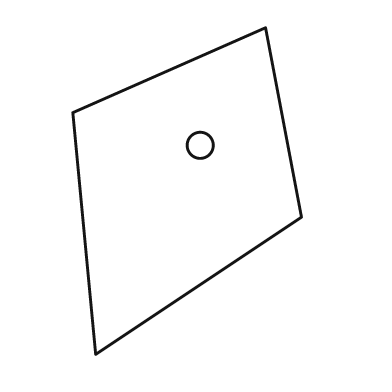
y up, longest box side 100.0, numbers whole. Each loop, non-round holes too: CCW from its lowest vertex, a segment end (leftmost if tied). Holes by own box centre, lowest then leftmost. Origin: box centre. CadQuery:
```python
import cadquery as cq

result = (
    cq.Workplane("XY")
    .moveTo(-28.0, -50.0)
    .lineTo(35.0, -8.0)
    .lineTo(24.0, 50.0)
    .lineTo(-35.0, 24.0)
    .close()
    .moveTo(4.0, 14.0)
    .circle(4.0)
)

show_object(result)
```